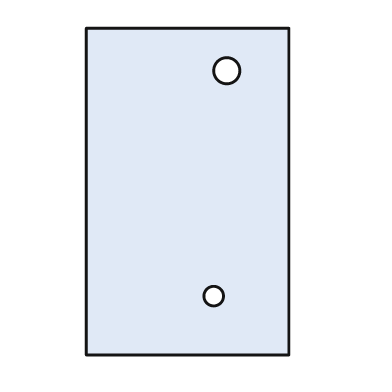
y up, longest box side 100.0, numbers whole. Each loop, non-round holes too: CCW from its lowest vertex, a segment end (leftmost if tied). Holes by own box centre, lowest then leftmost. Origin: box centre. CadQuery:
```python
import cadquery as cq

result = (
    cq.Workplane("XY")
    .moveTo(-31.0, -50.0)
    .lineTo(31.0, -50.0)
    .lineTo(31.0, 50.0)
    .lineTo(-31.0, 50.0)
    .close()
    .moveTo(8.0, -32.0)
    .circle(3.0)
    .moveTo(12.0, 37.0)
    .circle(4.0)
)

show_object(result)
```